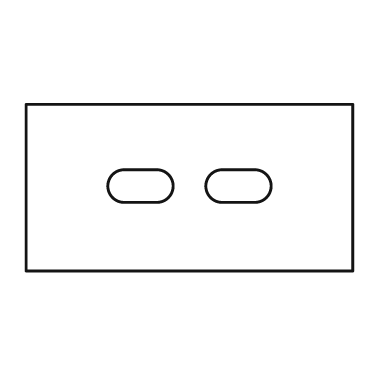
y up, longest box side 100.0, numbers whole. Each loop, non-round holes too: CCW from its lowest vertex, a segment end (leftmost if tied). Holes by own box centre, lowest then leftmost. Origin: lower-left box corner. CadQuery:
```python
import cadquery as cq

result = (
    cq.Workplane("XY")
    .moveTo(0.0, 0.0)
    .lineTo(100.0, 0.0)
    .lineTo(100.0, 51.0)
    .lineTo(0.0, 51.0)
    .close()
    .moveTo(30.0, 21.0)
    .lineTo(40.0, 21.0)
    .threePointArc((45.0, 26.0), (40.0, 31.0))
    .lineTo(30.0, 31.0)
    .threePointArc((25.0, 26.0), (30.0, 21.0))
    .close()
    .moveTo(60.0, 21.0)
    .lineTo(70.0, 21.0)
    .threePointArc((75.0, 26.0), (70.0, 31.0))
    .lineTo(60.0, 31.0)
    .threePointArc((55.0, 26.0), (60.0, 21.0))
    .close()
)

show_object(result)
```